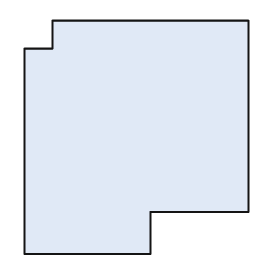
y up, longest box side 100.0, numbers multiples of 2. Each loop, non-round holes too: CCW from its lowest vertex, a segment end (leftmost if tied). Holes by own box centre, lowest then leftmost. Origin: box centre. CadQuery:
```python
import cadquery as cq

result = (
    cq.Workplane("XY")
    .moveTo(-48.0, -50.0)
    .lineTo(6.0, -50.0)
    .lineTo(6.0, -32.0)
    .lineTo(48.0, -32.0)
    .lineTo(48.0, 50.0)
    .lineTo(-36.0, 50.0)
    .lineTo(-36.0, 38.0)
    .lineTo(-48.0, 38.0)
    .close()
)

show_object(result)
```